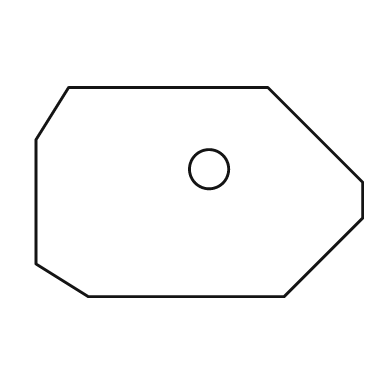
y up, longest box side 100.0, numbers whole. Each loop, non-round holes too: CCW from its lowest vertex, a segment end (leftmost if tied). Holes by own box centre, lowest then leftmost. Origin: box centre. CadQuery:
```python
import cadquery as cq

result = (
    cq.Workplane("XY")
    .moveTo(-34.0, -32.0)
    .lineTo(26.0, -32.0)
    .lineTo(50.0, -8.0)
    .lineTo(50.0, 3.0)
    .lineTo(21.0, 32.0)
    .lineTo(-40.0, 32.0)
    .lineTo(-50.0, 16.0)
    .lineTo(-50.0, -22.0)
    .close()
    .moveTo(3.0, 7.0)
    .circle(6.0)
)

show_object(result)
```